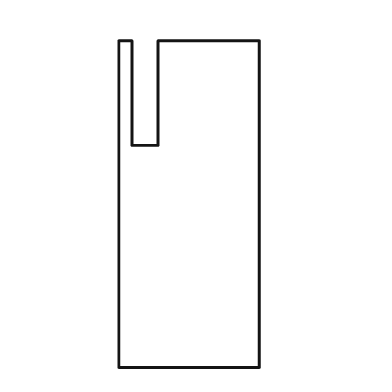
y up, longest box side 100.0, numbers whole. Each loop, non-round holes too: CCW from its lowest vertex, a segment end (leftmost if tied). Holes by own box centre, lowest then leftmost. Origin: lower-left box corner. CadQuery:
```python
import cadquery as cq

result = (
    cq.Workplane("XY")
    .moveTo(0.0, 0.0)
    .lineTo(43.0, 0.0)
    .lineTo(43.0, 100.0)
    .lineTo(12.0, 100.0)
    .lineTo(12.0, 68.0)
    .lineTo(4.0, 68.0)
    .lineTo(4.0, 100.0)
    .lineTo(0.0, 100.0)
    .close()
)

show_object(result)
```